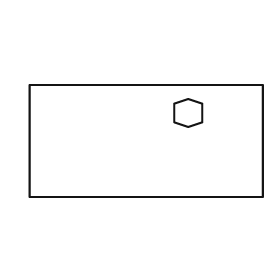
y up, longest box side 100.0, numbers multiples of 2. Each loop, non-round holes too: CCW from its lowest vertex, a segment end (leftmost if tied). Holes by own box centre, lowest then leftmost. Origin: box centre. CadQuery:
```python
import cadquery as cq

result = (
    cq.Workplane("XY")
    .moveTo(-50.0, -24.0)
    .lineTo(50.0, -24.0)
    .lineTo(50.0, 24.0)
    .lineTo(-50.0, 24.0)
    .close()
    .moveTo(18.0, 6.0)
    .lineTo(24.0, 8.0)
    .lineTo(24.0, 16.0)
    .lineTo(18.0, 18.0)
    .lineTo(12.0, 16.0)
    .lineTo(12.0, 8.0)
    .close()
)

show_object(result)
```